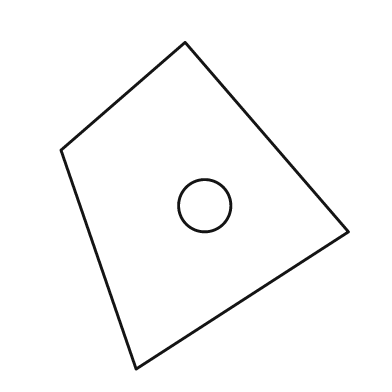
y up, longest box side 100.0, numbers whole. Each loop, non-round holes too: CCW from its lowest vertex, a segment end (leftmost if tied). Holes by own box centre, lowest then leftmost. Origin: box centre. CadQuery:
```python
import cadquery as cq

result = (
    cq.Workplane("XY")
    .moveTo(-21.0, -50.0)
    .lineTo(44.0, -8.0)
    .lineTo(-6.0, 50.0)
    .lineTo(-44.0, 17.0)
    .close()
    .moveTo(0.0, 0.0)
    .circle(8.0)
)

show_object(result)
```